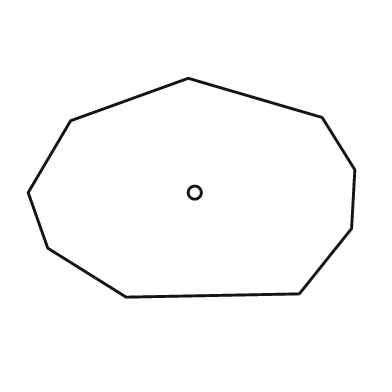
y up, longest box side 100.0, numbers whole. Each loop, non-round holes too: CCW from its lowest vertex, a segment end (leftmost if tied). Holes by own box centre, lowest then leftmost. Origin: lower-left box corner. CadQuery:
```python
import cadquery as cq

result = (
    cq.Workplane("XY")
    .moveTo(30.0, 0.0)
    .lineTo(83.0, 1.0)
    .lineTo(99.0, 21.0)
    .lineTo(100.0, 39.0)
    .lineTo(90.0, 55.0)
    .lineTo(49.0, 67.0)
    .lineTo(13.0, 54.0)
    .lineTo(0.0, 32.0)
    .lineTo(6.0, 15.0)
    .close()
    .moveTo(51.0, 32.0)
    .circle(2.0)
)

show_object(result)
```